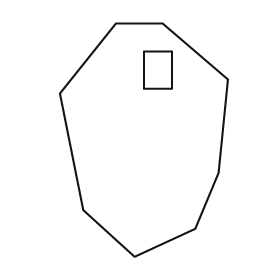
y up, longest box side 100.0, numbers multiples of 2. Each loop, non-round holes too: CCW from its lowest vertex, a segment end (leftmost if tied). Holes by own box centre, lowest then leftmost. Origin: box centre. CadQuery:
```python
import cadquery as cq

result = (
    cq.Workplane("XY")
    .moveTo(-4.0, -50.0)
    .lineTo(22.0, -38.0)
    .lineTo(32.0, -14.0)
    .lineTo(36.0, 26.0)
    .lineTo(8.0, 50.0)
    .lineTo(-12.0, 50.0)
    .lineTo(-36.0, 20.0)
    .lineTo(-26.0, -30.0)
    .close()
    .moveTo(0.0, 22.0)
    .lineTo(12.0, 22.0)
    .lineTo(12.0, 38.0)
    .lineTo(0.0, 38.0)
    .close()
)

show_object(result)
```